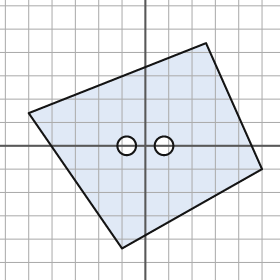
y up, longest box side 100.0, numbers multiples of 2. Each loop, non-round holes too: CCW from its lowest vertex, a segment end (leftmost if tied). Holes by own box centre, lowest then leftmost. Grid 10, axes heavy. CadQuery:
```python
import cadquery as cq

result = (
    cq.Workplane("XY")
    .moveTo(-10.0, -44.0)
    .lineTo(50.0, -10.0)
    .lineTo(26.0, 44.0)
    .lineTo(-50.0, 14.0)
    .close()
    .moveTo(-8.0, 0.0)
    .circle(4.0)
    .moveTo(8.0, 0.0)
    .circle(4.0)
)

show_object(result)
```